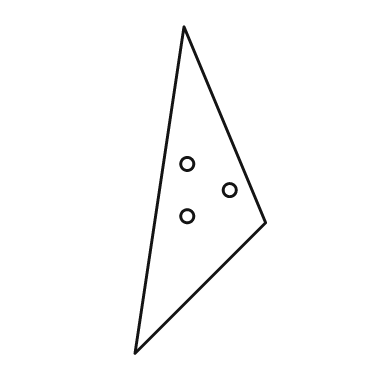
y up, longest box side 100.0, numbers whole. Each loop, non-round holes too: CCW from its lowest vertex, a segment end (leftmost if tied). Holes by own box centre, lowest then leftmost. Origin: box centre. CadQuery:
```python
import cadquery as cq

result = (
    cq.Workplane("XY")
    .moveTo(-20.0, -50.0)
    .lineTo(20.0, -10.0)
    .lineTo(-5.0, 50.0)
    .close()
    .moveTo(-4.0, -8.0)
    .circle(2.0)
    .moveTo(9.0, 0.0)
    .circle(2.0)
    .moveTo(-4.0, 8.0)
    .circle(2.0)
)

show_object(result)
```